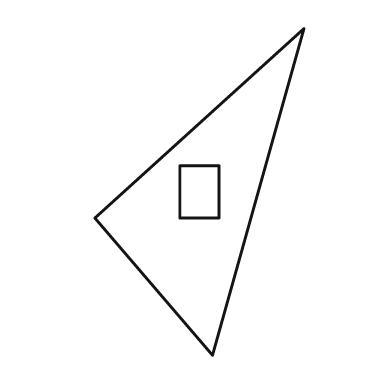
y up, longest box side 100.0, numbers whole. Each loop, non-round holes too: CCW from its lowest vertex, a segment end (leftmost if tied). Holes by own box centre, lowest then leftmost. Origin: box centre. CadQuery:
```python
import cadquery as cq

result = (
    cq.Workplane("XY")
    .moveTo(4.0, -50.0)
    .lineTo(32.0, 50.0)
    .lineTo(-32.0, -8.0)
    .close()
    .moveTo(-6.0, -8.0)
    .lineTo(6.0, -8.0)
    .lineTo(6.0, 8.0)
    .lineTo(-6.0, 8.0)
    .close()
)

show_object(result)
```